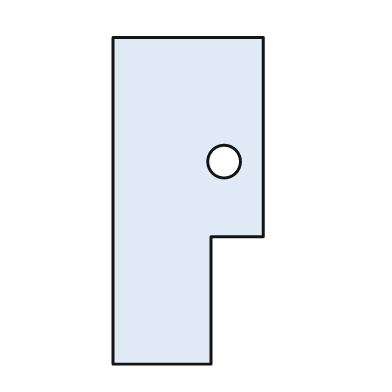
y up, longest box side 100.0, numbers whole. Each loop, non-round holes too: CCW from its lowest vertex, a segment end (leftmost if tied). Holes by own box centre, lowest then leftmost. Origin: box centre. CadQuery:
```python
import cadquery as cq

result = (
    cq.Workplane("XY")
    .moveTo(-23.0, -50.0)
    .lineTo(7.0, -50.0)
    .lineTo(7.0, -11.0)
    .lineTo(23.0, -11.0)
    .lineTo(23.0, 50.0)
    .lineTo(-23.0, 50.0)
    .close()
    .moveTo(11.0, 12.0)
    .circle(5.0)
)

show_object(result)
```